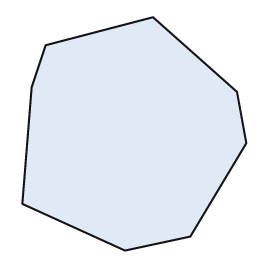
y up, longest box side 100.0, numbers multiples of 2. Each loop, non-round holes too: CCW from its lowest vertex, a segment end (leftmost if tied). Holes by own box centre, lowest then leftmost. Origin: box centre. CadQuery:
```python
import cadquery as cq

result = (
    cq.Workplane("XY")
    .moveTo(-4.0, -50.0)
    .lineTo(24.0, -44.0)
    .lineTo(48.0, -4.0)
    .lineTo(44.0, 18.0)
    .lineTo(8.0, 50.0)
    .lineTo(-38.0, 38.0)
    .lineTo(-44.0, 20.0)
    .lineTo(-48.0, -30.0)
    .close()
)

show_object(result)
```